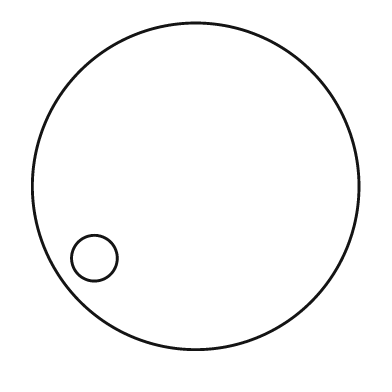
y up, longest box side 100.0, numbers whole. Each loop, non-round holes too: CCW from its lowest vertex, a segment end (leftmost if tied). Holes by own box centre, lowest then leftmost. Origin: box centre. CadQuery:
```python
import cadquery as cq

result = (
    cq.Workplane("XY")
    .moveTo(0.0, 0.0)
    .circle(50.0)
    .moveTo(-31.0, -22.0)
    .circle(7.0)
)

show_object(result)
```